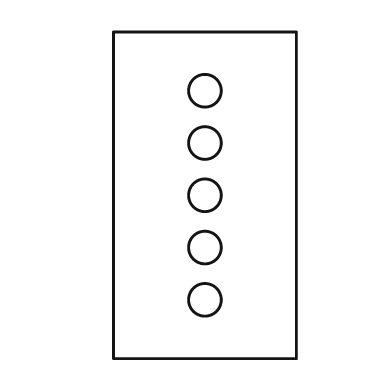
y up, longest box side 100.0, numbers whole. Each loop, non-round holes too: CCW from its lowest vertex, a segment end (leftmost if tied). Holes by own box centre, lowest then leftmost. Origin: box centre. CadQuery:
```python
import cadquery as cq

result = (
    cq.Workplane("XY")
    .moveTo(-28.0, -50.0)
    .lineTo(28.0, -50.0)
    .lineTo(28.0, 50.0)
    .lineTo(-28.0, 50.0)
    .close()
    .moveTo(0.0, -32.0)
    .circle(5.0)
    .moveTo(0.0, -16.0)
    .circle(5.0)
    .moveTo(0.0, 0.0)
    .circle(5.0)
    .moveTo(0.0, 16.0)
    .circle(5.0)
    .moveTo(0.0, 32.0)
    .circle(5.0)
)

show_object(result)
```